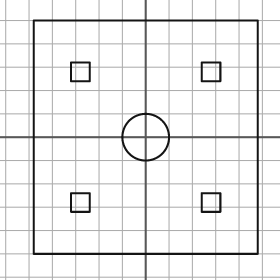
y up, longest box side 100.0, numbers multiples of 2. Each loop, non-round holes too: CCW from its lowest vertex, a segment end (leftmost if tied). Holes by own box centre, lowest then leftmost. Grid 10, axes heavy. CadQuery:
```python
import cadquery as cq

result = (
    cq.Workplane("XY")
    .moveTo(-48.0, -50.0)
    .lineTo(48.0, -50.0)
    .lineTo(48.0, 50.0)
    .lineTo(-48.0, 50.0)
    .close()
    .moveTo(-32.0, -32.0)
    .lineTo(-24.0, -32.0)
    .lineTo(-24.0, -24.0)
    .lineTo(-32.0, -24.0)
    .close()
    .moveTo(24.0, -32.0)
    .lineTo(32.0, -32.0)
    .lineTo(32.0, -24.0)
    .lineTo(24.0, -24.0)
    .close()
    .moveTo(0.0, 0.0)
    .circle(10.0)
    .moveTo(-32.0, 24.0)
    .lineTo(-24.0, 24.0)
    .lineTo(-24.0, 32.0)
    .lineTo(-32.0, 32.0)
    .close()
    .moveTo(24.0, 24.0)
    .lineTo(32.0, 24.0)
    .lineTo(32.0, 32.0)
    .lineTo(24.0, 32.0)
    .close()
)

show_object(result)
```